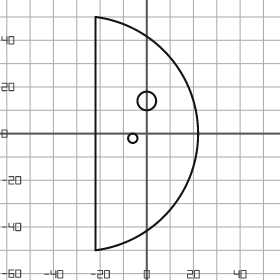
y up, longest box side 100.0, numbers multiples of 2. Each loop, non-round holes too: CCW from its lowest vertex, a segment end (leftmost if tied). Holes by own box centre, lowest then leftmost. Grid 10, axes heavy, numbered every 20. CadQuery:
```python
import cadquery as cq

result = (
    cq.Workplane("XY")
    .moveTo(-22.0, -50.0)
    .threePointArc((22.0, 0.0), (-22.0, 50.0))
    .close()
    .moveTo(-6.0, -2.0)
    .circle(2.0)
    .moveTo(0.0, 14.0)
    .circle(4.0)
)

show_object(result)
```